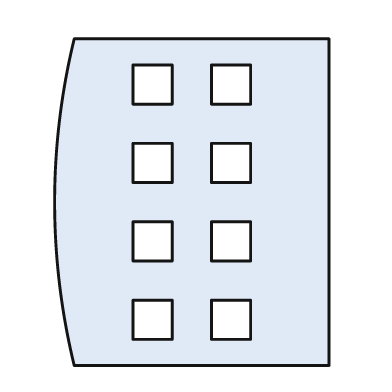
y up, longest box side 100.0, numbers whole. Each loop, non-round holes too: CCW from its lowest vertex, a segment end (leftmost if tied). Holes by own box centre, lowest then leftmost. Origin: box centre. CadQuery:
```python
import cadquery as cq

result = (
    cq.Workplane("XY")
    .moveTo(-36.0, -50.0)
    .lineTo(42.0, -50.0)
    .lineTo(42.0, 50.0)
    .lineTo(-36.0, 50.0)
    .threePointArc((-42.0, 0.0), (-36.0, -50.0))
    .close()
    .moveTo(-18.0, -42.0)
    .lineTo(-6.0, -42.0)
    .lineTo(-6.0, -30.0)
    .lineTo(-18.0, -30.0)
    .close()
    .moveTo(6.0, -42.0)
    .lineTo(18.0, -42.0)
    .lineTo(18.0, -30.0)
    .lineTo(6.0, -30.0)
    .close()
    .moveTo(-18.0, -18.0)
    .lineTo(-6.0, -18.0)
    .lineTo(-6.0, -6.0)
    .lineTo(-18.0, -6.0)
    .close()
    .moveTo(6.0, -18.0)
    .lineTo(18.0, -18.0)
    .lineTo(18.0, -6.0)
    .lineTo(6.0, -6.0)
    .close()
    .moveTo(-18.0, 6.0)
    .lineTo(-6.0, 6.0)
    .lineTo(-6.0, 18.0)
    .lineTo(-18.0, 18.0)
    .close()
    .moveTo(6.0, 6.0)
    .lineTo(18.0, 6.0)
    .lineTo(18.0, 18.0)
    .lineTo(6.0, 18.0)
    .close()
    .moveTo(-18.0, 30.0)
    .lineTo(-6.0, 30.0)
    .lineTo(-6.0, 42.0)
    .lineTo(-18.0, 42.0)
    .close()
    .moveTo(6.0, 30.0)
    .lineTo(18.0, 30.0)
    .lineTo(18.0, 42.0)
    .lineTo(6.0, 42.0)
    .close()
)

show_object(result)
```